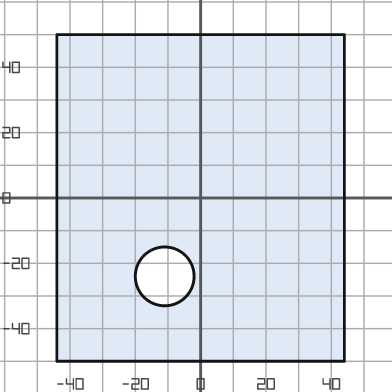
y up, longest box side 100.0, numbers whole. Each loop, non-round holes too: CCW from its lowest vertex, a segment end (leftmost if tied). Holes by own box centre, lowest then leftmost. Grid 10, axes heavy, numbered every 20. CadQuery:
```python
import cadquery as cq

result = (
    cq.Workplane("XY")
    .moveTo(-44.0, -50.0)
    .lineTo(44.0, -50.0)
    .lineTo(44.0, 50.0)
    .lineTo(-44.0, 50.0)
    .close()
    .moveTo(-11.0, -24.0)
    .circle(9.0)
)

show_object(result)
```